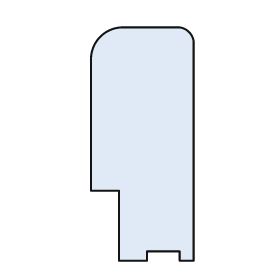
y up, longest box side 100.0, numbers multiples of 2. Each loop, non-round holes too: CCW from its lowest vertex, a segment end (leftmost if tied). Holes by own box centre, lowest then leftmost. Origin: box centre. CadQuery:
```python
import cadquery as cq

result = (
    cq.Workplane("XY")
    .moveTo(-10.0, -50.0)
    .lineTo(2.0, -50.0)
    .lineTo(2.0, -46.0)
    .lineTo(16.0, -46.0)
    .lineTo(16.0, -50.0)
    .lineTo(22.0, -50.0)
    .lineTo(22.0, 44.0)
    .threePointArc((20.0, 48.0), (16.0, 50.0))
    .lineTo(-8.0, 50.0)
    .threePointArc((-18.0, 46.0), (-22.0, 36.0))
    .lineTo(-22.0, -20.0)
    .lineTo(-10.0, -20.0)
    .close()
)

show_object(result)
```